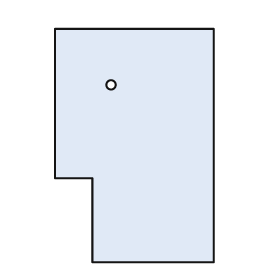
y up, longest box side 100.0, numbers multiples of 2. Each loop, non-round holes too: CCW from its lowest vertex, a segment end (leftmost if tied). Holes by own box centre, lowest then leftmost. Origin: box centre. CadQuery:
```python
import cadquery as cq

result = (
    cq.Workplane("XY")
    .moveTo(-18.0, -50.0)
    .lineTo(34.0, -50.0)
    .lineTo(34.0, 50.0)
    .lineTo(-34.0, 50.0)
    .lineTo(-34.0, -14.0)
    .lineTo(-18.0, -14.0)
    .close()
    .moveTo(-10.0, 26.0)
    .circle(2.0)
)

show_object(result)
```